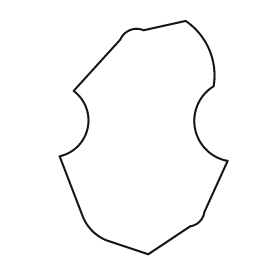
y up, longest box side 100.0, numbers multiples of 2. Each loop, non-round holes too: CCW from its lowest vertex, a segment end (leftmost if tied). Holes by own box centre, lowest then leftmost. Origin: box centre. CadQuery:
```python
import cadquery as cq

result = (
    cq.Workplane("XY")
    .moveTo(2.0, -50.0)
    .lineTo(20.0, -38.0)
    .threePointArc((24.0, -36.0), (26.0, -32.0))
    .lineTo(36.0, -10.0)
    .threePointArc((22.0, 4.0), (30.0, 22.0))
    .threePointArc((28.0, 38.0), (18.0, 50.0))
    .lineTo(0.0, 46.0)
    .threePointArc((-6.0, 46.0), (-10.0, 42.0))
    .lineTo(-30.0, 20.0)
    .threePointArc((-24.0, 4.0), (-36.0, -8.0))
    .lineTo(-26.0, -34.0)
    .threePointArc((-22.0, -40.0), (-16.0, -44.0))
    .close()
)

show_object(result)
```